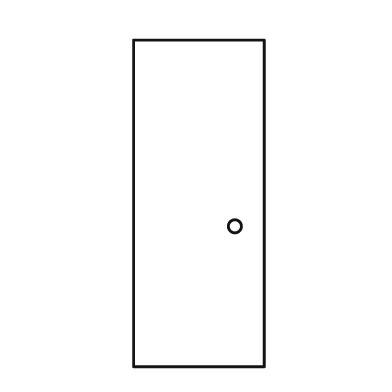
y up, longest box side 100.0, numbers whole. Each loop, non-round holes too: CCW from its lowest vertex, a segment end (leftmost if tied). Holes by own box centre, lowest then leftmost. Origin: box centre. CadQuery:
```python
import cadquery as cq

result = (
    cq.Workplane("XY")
    .moveTo(-20.0, -50.0)
    .lineTo(20.0, -50.0)
    .lineTo(20.0, 50.0)
    .lineTo(-20.0, 50.0)
    .close()
    .moveTo(11.0, -7.0)
    .circle(2.0)
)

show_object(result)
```